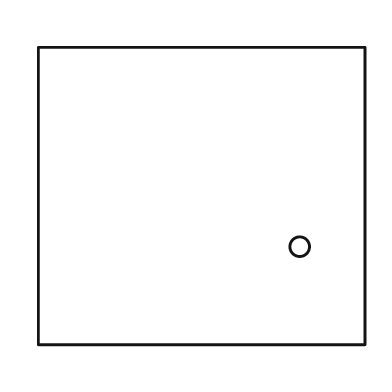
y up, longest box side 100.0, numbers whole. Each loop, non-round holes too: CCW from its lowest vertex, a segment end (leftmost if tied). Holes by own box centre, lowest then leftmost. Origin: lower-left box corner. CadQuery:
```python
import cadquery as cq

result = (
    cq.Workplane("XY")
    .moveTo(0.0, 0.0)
    .lineTo(100.0, 0.0)
    .lineTo(100.0, 91.0)
    .lineTo(0.0, 91.0)
    .close()
    .moveTo(80.0, 30.0)
    .circle(3.0)
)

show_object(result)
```